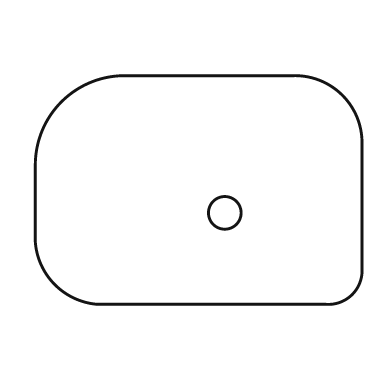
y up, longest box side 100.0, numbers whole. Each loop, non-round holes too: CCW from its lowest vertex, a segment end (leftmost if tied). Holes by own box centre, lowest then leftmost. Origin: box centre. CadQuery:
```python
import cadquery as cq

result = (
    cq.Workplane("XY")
    .moveTo(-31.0, -35.0)
    .lineTo(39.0, -35.0)
    .threePointArc((47.0, -32.0), (50.0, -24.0))
    .lineTo(50.0, 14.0)
    .threePointArc((44.0, 29.0), (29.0, 35.0))
    .lineTo(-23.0, 35.0)
    .threePointArc((-42.0, 27.0), (-50.0, 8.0))
    .lineTo(-50.0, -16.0)
    .threePointArc((-44.0, -29.0), (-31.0, -35.0))
    .close()
    .moveTo(8.0, -7.0)
    .circle(5.0)
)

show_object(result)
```